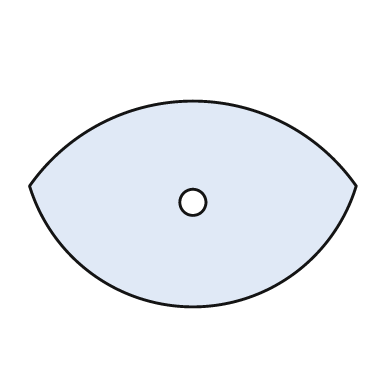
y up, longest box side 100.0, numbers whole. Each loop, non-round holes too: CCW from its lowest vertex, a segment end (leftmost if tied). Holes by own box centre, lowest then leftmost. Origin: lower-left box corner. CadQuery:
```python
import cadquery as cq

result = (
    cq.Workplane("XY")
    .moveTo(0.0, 37.0)
    .threePointArc((50.0, 0.0), (100.0, 37.0))
    .threePointArc((50.0, 63.0), (0.0, 37.0))
    .close()
    .moveTo(50.0, 32.0)
    .circle(4.0)
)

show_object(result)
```